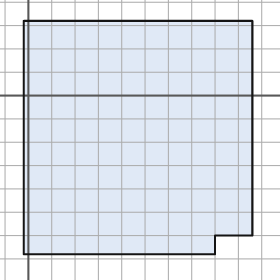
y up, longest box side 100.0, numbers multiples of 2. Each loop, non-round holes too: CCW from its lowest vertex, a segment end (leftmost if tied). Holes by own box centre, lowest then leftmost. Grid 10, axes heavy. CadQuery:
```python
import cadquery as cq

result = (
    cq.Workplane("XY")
    .moveTo(-2.0, -68.0)
    .lineTo(80.0, -68.0)
    .lineTo(80.0, -60.0)
    .lineTo(96.0, -60.0)
    .lineTo(96.0, 32.0)
    .lineTo(-2.0, 32.0)
    .close()
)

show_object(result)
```